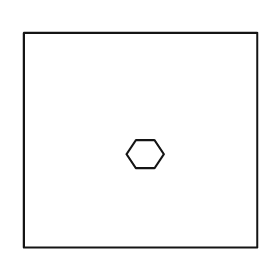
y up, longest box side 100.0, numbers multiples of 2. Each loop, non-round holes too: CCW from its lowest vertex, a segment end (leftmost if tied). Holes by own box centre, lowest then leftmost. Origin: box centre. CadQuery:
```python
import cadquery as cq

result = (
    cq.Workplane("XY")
    .moveTo(-50.0, -46.0)
    .lineTo(50.0, -46.0)
    .lineTo(50.0, 46.0)
    .lineTo(-50.0, 46.0)
    .close()
    .moveTo(-2.0, -12.0)
    .lineTo(6.0, -12.0)
    .lineTo(10.0, -6.0)
    .lineTo(6.0, 0.0)
    .lineTo(-2.0, 0.0)
    .lineTo(-6.0, -6.0)
    .close()
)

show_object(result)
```